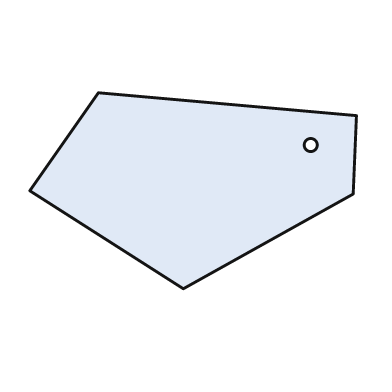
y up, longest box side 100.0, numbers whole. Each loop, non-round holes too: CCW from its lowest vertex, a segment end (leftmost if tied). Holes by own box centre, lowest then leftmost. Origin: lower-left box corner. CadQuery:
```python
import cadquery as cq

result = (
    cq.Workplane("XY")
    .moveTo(47.0, 0.0)
    .lineTo(99.0, 29.0)
    .lineTo(100.0, 53.0)
    .lineTo(21.0, 60.0)
    .lineTo(0.0, 30.0)
    .close()
    .moveTo(86.0, 44.0)
    .circle(2.0)
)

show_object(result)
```